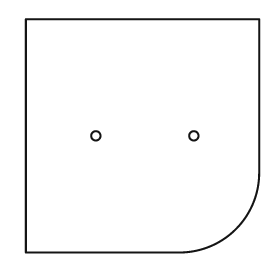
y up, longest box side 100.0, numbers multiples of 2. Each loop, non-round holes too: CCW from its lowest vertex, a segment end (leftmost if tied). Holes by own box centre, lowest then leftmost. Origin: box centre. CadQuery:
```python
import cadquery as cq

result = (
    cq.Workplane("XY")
    .moveTo(-50.0, -50.0)
    .lineTo(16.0, -50.0)
    .threePointArc((40.0, -40.0), (50.0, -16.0))
    .lineTo(50.0, 50.0)
    .lineTo(-50.0, 50.0)
    .close()
    .moveTo(-20.0, 0.0)
    .circle(2.0)
    .moveTo(22.0, 0.0)
    .circle(2.0)
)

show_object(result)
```